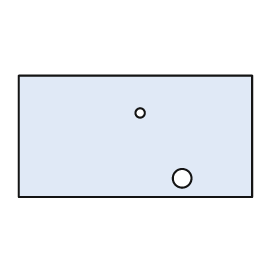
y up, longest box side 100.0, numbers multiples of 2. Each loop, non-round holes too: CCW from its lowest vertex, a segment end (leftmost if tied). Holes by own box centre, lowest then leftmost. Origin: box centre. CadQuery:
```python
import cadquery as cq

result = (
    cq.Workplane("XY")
    .moveTo(-50.0, -26.0)
    .lineTo(50.0, -26.0)
    .lineTo(50.0, 26.0)
    .lineTo(-50.0, 26.0)
    .close()
    .moveTo(20.0, -18.0)
    .circle(4.0)
    .moveTo(2.0, 10.0)
    .circle(2.0)
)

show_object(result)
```